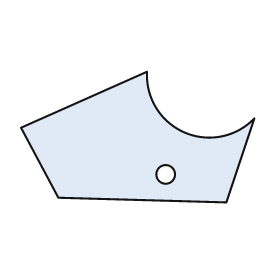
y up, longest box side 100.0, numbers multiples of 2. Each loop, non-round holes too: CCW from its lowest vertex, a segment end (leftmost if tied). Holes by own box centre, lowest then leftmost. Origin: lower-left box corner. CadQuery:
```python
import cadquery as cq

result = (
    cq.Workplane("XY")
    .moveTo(88.0, 0.0)
    .lineTo(100.0, 36.0)
    .threePointArc((70.0, 30.0), (54.0, 56.0))
    .lineTo(0.0, 32.0)
    .lineTo(16.0, 2.0)
    .close()
    .moveTo(62.0, 12.0)
    .circle(4.0)
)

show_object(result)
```